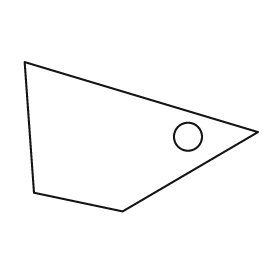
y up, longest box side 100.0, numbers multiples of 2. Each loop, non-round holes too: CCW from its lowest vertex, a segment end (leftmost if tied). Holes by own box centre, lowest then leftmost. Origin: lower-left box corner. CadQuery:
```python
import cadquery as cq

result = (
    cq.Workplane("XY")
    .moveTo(42.0, 0.0)
    .lineTo(100.0, 34.0)
    .lineTo(0.0, 64.0)
    .lineTo(4.0, 8.0)
    .close()
    .moveTo(70.0, 32.0)
    .circle(6.0)
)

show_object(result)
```